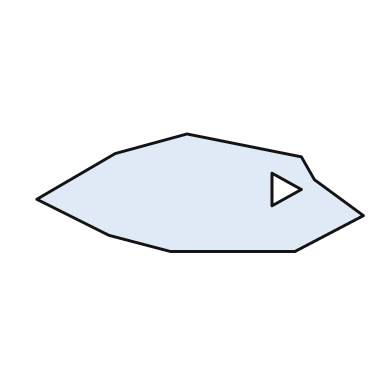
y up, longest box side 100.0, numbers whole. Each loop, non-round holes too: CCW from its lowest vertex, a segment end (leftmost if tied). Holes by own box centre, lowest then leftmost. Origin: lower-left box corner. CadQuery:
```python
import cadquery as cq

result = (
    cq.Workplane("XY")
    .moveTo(41.0, 0.0)
    .lineTo(79.0, 0.0)
    .lineTo(100.0, 11.0)
    .lineTo(85.0, 22.0)
    .lineTo(81.0, 29.0)
    .lineTo(46.0, 36.0)
    .lineTo(24.0, 30.0)
    .lineTo(0.0, 16.0)
    .lineTo(22.0, 5.0)
    .close()
    .moveTo(72.0, 14.0)
    .lineTo(81.0, 19.0)
    .lineTo(72.0, 24.0)
    .close()
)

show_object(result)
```